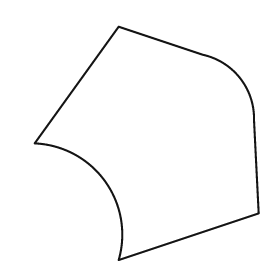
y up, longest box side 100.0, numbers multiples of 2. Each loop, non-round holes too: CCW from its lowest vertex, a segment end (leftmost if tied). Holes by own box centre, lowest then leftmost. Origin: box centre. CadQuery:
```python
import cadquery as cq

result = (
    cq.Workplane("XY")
    .moveTo(-12.0, -50.0)
    .lineTo(48.0, -30.0)
    .lineTo(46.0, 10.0)
    .threePointArc((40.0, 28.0), (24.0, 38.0))
    .lineTo(-12.0, 50.0)
    .lineTo(-48.0, 0.0)
    .threePointArc((-18.0, -16.0), (-12.0, -50.0))
    .close()
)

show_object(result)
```